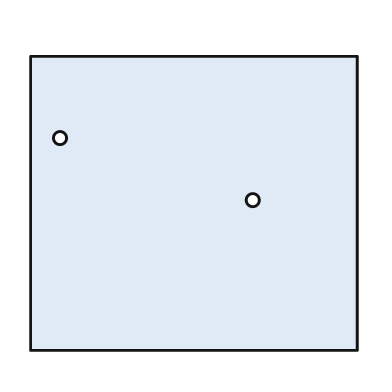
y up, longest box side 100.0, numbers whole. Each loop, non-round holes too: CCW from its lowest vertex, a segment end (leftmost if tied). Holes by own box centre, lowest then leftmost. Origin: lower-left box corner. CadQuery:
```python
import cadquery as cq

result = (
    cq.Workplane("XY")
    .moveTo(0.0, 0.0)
    .lineTo(100.0, 0.0)
    .lineTo(100.0, 90.0)
    .lineTo(0.0, 90.0)
    .close()
    .moveTo(68.0, 46.0)
    .circle(2.0)
    .moveTo(9.0, 65.0)
    .circle(2.0)
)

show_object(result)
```